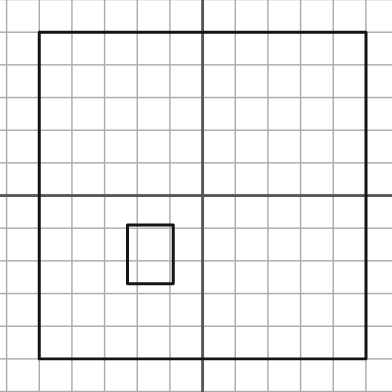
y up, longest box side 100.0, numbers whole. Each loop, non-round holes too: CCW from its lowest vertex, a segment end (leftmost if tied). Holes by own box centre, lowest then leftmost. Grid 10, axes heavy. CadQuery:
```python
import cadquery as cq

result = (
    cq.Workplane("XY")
    .moveTo(-50.0, -50.0)
    .lineTo(50.0, -50.0)
    .lineTo(50.0, 50.0)
    .lineTo(-50.0, 50.0)
    .close()
    .moveTo(-23.0, -27.0)
    .lineTo(-9.0, -27.0)
    .lineTo(-9.0, -9.0)
    .lineTo(-23.0, -9.0)
    .close()
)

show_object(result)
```